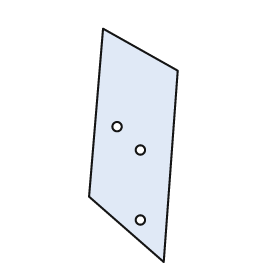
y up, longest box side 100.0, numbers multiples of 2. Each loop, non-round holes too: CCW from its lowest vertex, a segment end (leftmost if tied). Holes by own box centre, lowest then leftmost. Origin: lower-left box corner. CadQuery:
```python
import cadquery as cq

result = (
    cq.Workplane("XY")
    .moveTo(32.0, 0.0)
    .lineTo(38.0, 82.0)
    .lineTo(6.0, 100.0)
    .lineTo(0.0, 28.0)
    .close()
    .moveTo(22.0, 18.0)
    .circle(2.0)
    .moveTo(22.0, 48.0)
    .circle(2.0)
    .moveTo(12.0, 58.0)
    .circle(2.0)
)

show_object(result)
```